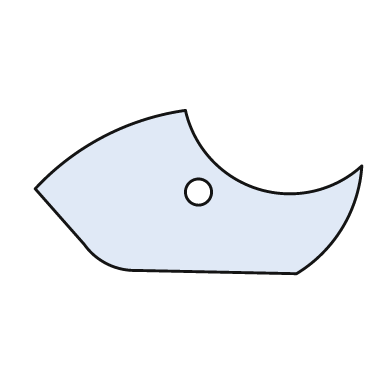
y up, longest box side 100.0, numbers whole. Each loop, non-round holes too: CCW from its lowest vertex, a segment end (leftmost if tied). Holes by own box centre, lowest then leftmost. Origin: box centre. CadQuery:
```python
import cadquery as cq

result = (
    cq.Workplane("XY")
    .moveTo(30.0, -25.0)
    .threePointArc((44.0, -11.0), (50.0, 8.0))
    .threePointArc((18.0, 1.0), (-4.0, 25.0))
    .threePointArc((-29.0, 17.0), (-50.0, 1.0))
    .lineTo(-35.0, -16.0)
    .threePointArc((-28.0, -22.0), (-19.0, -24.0))
    .close()
    .moveTo(0.0, 0.0)
    .circle(4.0)
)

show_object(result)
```